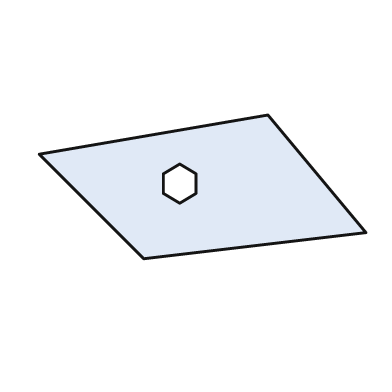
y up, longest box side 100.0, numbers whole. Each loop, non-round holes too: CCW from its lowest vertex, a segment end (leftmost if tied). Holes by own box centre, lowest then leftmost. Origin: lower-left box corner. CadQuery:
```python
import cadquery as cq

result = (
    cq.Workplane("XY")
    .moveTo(32.0, 0.0)
    .lineTo(100.0, 8.0)
    .lineTo(70.0, 44.0)
    .lineTo(0.0, 32.0)
    .close()
    .moveTo(43.0, 17.0)
    .lineTo(48.0, 20.0)
    .lineTo(48.0, 26.0)
    .lineTo(43.0, 29.0)
    .lineTo(38.0, 26.0)
    .lineTo(38.0, 20.0)
    .close()
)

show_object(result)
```